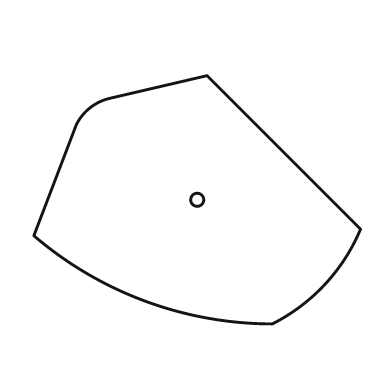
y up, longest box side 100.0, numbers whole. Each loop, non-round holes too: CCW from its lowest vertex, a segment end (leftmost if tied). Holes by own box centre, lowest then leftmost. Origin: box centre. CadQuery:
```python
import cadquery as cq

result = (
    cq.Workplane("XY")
    .moveTo(23.0, -38.0)
    .threePointArc((39.0, -26.0), (50.0, -9.0))
    .lineTo(3.0, 38.0)
    .lineTo(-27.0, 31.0)
    .threePointArc((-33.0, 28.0), (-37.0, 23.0))
    .lineTo(-50.0, -11.0)
    .threePointArc((-16.0, -31.0), (23.0, -38.0))
    .close()
    .moveTo(0.0, 0.0)
    .circle(2.0)
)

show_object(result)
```